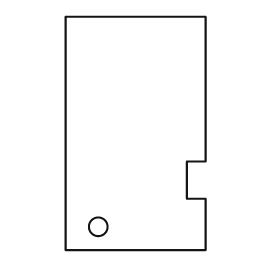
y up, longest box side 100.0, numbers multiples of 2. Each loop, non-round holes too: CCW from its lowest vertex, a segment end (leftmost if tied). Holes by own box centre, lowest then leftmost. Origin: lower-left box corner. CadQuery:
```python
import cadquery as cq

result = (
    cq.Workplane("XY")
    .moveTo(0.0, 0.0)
    .lineTo(60.0, 0.0)
    .lineTo(60.0, 22.0)
    .lineTo(52.0, 22.0)
    .lineTo(52.0, 38.0)
    .lineTo(60.0, 38.0)
    .lineTo(60.0, 100.0)
    .lineTo(0.0, 100.0)
    .close()
    .moveTo(14.0, 10.0)
    .circle(4.0)
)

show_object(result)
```